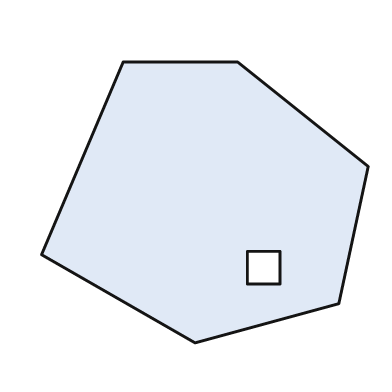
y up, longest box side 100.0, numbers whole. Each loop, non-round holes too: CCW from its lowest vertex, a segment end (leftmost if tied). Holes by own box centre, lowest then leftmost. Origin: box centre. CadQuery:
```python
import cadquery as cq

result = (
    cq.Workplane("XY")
    .moveTo(-3.0, -43.0)
    .lineTo(41.0, -31.0)
    .lineTo(50.0, 11.0)
    .lineTo(10.0, 43.0)
    .lineTo(-25.0, 43.0)
    .lineTo(-50.0, -16.0)
    .close()
    .moveTo(13.0, -25.0)
    .lineTo(23.0, -25.0)
    .lineTo(23.0, -15.0)
    .lineTo(13.0, -15.0)
    .close()
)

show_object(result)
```